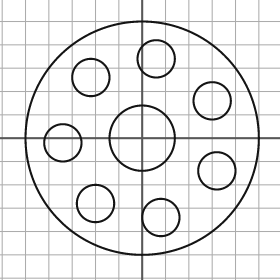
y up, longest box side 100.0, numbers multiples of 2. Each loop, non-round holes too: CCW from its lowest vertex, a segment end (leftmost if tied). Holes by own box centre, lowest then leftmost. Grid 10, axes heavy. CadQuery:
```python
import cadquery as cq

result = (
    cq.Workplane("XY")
    .moveTo(0.0, 0.0)
    .circle(50.0)
    .moveTo(8.0, -34.0)
    .circle(8.0)
    .moveTo(-20.0, -28.0)
    .circle(8.0)
    .moveTo(32.0, -14.0)
    .circle(8.0)
    .moveTo(-34.0, -2.0)
    .circle(8.0)
    .moveTo(0.0, 0.0)
    .circle(14.0)
    .moveTo(30.0, 16.0)
    .circle(8.0)
    .moveTo(-22.0, 26.0)
    .circle(8.0)
    .moveTo(6.0, 34.0)
    .circle(8.0)
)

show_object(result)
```